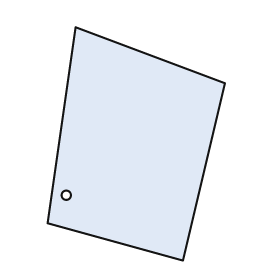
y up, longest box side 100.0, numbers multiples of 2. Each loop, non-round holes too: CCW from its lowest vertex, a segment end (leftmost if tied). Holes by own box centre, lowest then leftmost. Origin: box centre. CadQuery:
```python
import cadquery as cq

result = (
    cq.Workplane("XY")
    .moveTo(20.0, -50.0)
    .lineTo(38.0, 26.0)
    .lineTo(-26.0, 50.0)
    .lineTo(-38.0, -34.0)
    .close()
    .moveTo(-30.0, -22.0)
    .circle(2.0)
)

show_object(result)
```